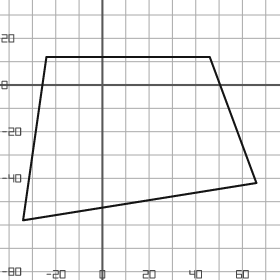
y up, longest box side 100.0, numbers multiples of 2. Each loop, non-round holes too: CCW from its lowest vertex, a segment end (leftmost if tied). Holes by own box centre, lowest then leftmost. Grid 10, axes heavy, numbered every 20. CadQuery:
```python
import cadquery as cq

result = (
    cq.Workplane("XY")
    .moveTo(-34.0, -58.0)
    .lineTo(66.0, -42.0)
    .lineTo(46.0, 12.0)
    .lineTo(-24.0, 12.0)
    .close()
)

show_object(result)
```